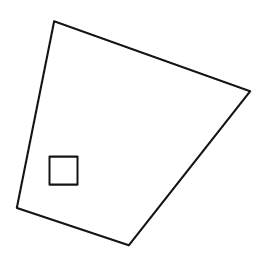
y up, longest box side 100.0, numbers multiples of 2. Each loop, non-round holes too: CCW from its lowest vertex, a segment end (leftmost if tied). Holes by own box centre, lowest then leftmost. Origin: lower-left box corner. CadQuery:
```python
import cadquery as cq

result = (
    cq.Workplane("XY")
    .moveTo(48.0, 0.0)
    .lineTo(100.0, 66.0)
    .lineTo(16.0, 96.0)
    .lineTo(0.0, 16.0)
    .close()
    .moveTo(14.0, 26.0)
    .lineTo(26.0, 26.0)
    .lineTo(26.0, 38.0)
    .lineTo(14.0, 38.0)
    .close()
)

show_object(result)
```